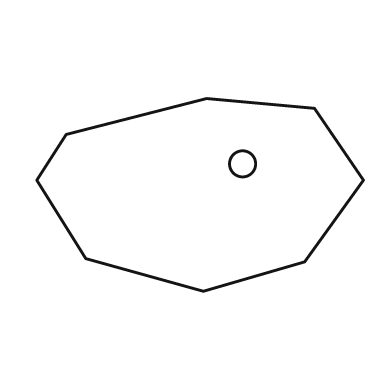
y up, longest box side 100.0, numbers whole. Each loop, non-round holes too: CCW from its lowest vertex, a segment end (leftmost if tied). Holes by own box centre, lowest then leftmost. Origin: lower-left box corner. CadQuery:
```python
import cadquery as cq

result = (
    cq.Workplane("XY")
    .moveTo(51.0, 0.0)
    .lineTo(82.0, 9.0)
    .lineTo(100.0, 34.0)
    .lineTo(85.0, 56.0)
    .lineTo(52.0, 59.0)
    .lineTo(9.0, 48.0)
    .lineTo(0.0, 34.0)
    .lineTo(15.0, 10.0)
    .close()
    .moveTo(63.0, 39.0)
    .circle(4.0)
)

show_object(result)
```